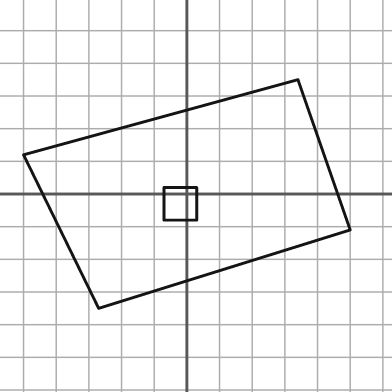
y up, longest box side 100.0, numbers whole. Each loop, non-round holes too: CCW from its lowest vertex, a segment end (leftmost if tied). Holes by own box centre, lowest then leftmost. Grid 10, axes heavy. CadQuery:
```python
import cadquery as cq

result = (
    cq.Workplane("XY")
    .moveTo(-27.0, -35.0)
    .lineTo(50.0, -11.0)
    .lineTo(34.0, 35.0)
    .lineTo(-50.0, 12.0)
    .close()
    .moveTo(-7.0, -8.0)
    .lineTo(3.0, -8.0)
    .lineTo(3.0, 2.0)
    .lineTo(-7.0, 2.0)
    .close()
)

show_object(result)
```